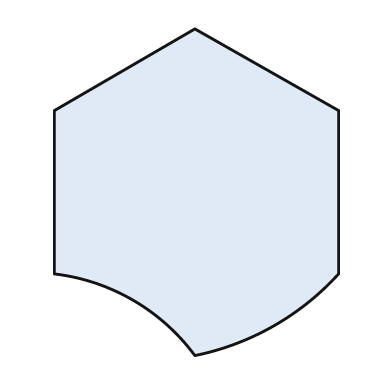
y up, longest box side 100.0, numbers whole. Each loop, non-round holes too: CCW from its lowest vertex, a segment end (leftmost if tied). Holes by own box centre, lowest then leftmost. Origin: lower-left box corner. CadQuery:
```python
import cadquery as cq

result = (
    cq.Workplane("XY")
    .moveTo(43.0, 0.0)
    .threePointArc((67.0, 9.0), (87.0, 25.0))
    .lineTo(87.0, 75.0)
    .lineTo(43.0, 100.0)
    .lineTo(0.0, 75.0)
    .lineTo(0.0, 25.0)
    .threePointArc((24.0, 17.0), (43.0, 0.0))
    .close()
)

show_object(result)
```